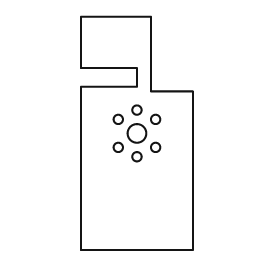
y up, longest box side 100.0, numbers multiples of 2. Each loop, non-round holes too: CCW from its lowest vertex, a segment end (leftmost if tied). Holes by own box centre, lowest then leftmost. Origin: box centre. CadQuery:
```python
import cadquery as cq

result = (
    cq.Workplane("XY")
    .moveTo(-24.0, -50.0)
    .lineTo(24.0, -50.0)
    .lineTo(24.0, 18.0)
    .lineTo(6.0, 18.0)
    .lineTo(6.0, 50.0)
    .lineTo(-24.0, 50.0)
    .lineTo(-24.0, 28.0)
    .lineTo(0.0, 28.0)
    .lineTo(0.0, 20.0)
    .lineTo(-24.0, 20.0)
    .close()
    .moveTo(0.0, -10.0)
    .circle(2.0)
    .moveTo(-8.0, -6.0)
    .circle(2.0)
    .moveTo(8.0, -6.0)
    .circle(2.0)
    .moveTo(0.0, 0.0)
    .circle(4.0)
    .moveTo(-8.0, 6.0)
    .circle(2.0)
    .moveTo(8.0, 6.0)
    .circle(2.0)
    .moveTo(0.0, 10.0)
    .circle(2.0)
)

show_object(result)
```